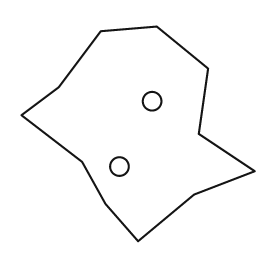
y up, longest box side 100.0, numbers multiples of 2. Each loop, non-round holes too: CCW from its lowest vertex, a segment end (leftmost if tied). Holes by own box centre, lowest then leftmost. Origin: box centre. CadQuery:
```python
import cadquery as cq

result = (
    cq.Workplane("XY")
    .moveTo(0.0, -46.0)
    .lineTo(24.0, -26.0)
    .lineTo(50.0, -16.0)
    .lineTo(26.0, 0.0)
    .lineTo(30.0, 28.0)
    .lineTo(8.0, 46.0)
    .lineTo(-16.0, 44.0)
    .lineTo(-34.0, 20.0)
    .lineTo(-50.0, 8.0)
    .lineTo(-24.0, -12.0)
    .lineTo(-14.0, -30.0)
    .close()
    .moveTo(-8.0, -14.0)
    .circle(4.0)
    .moveTo(6.0, 14.0)
    .circle(4.0)
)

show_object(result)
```